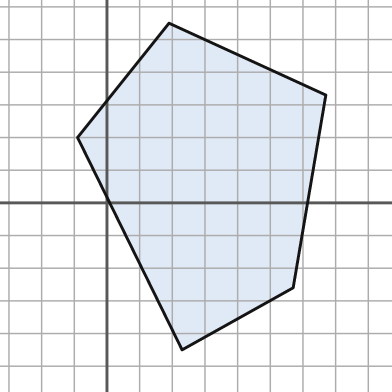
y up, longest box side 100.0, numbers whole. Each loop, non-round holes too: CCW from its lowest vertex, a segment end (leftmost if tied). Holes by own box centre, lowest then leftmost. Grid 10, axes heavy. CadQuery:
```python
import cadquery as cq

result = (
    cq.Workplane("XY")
    .moveTo(23.0, -45.0)
    .lineTo(57.0, -26.0)
    .lineTo(67.0, 33.0)
    .lineTo(19.0, 55.0)
    .lineTo(-9.0, 20.0)
    .close()
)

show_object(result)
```